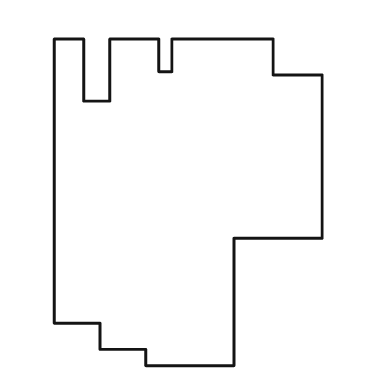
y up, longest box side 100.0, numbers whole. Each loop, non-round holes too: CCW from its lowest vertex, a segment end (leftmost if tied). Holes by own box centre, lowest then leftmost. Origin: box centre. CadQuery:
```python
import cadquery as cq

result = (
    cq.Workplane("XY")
    .moveTo(-13.0, -50.0)
    .lineTo(14.0, -50.0)
    .lineTo(14.0, -11.0)
    .lineTo(41.0, -11.0)
    .lineTo(41.0, 39.0)
    .lineTo(26.0, 39.0)
    .lineTo(26.0, 50.0)
    .lineTo(-5.0, 50.0)
    .lineTo(-5.0, 40.0)
    .lineTo(-9.0, 40.0)
    .lineTo(-9.0, 50.0)
    .lineTo(-24.0, 50.0)
    .lineTo(-24.0, 31.0)
    .lineTo(-32.0, 31.0)
    .lineTo(-32.0, 50.0)
    .lineTo(-41.0, 50.0)
    .lineTo(-41.0, -37.0)
    .lineTo(-27.0, -37.0)
    .lineTo(-27.0, -45.0)
    .lineTo(-13.0, -45.0)
    .close()
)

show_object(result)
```